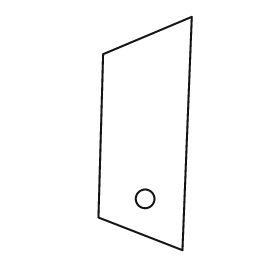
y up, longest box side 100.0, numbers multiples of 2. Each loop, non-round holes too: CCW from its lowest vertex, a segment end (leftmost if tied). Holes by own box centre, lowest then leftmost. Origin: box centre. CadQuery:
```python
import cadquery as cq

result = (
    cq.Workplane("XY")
    .moveTo(16.0, -50.0)
    .lineTo(20.0, 50.0)
    .lineTo(-18.0, 34.0)
    .lineTo(-20.0, -36.0)
    .close()
    .moveTo(0.0, -28.0)
    .circle(4.0)
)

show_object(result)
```